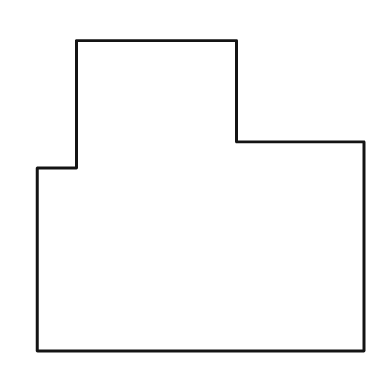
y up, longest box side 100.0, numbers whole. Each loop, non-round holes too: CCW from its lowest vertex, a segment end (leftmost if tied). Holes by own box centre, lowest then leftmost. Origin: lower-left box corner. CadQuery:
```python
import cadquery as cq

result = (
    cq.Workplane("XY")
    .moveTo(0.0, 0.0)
    .lineTo(100.0, 0.0)
    .lineTo(100.0, 64.0)
    .lineTo(61.0, 64.0)
    .lineTo(61.0, 95.0)
    .lineTo(12.0, 95.0)
    .lineTo(12.0, 56.0)
    .lineTo(0.0, 56.0)
    .close()
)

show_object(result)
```